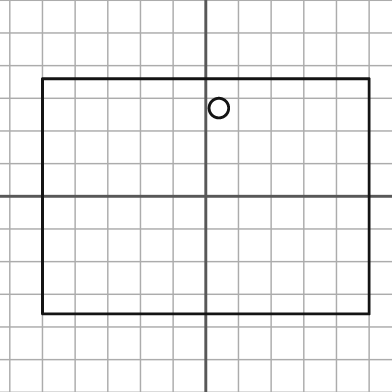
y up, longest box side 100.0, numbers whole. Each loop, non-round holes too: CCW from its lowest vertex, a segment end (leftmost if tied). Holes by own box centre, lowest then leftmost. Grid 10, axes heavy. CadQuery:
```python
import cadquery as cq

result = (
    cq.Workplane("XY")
    .moveTo(-50.0, -36.0)
    .lineTo(50.0, -36.0)
    .lineTo(50.0, 36.0)
    .lineTo(-50.0, 36.0)
    .close()
    .moveTo(4.0, 27.0)
    .circle(3.0)
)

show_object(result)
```